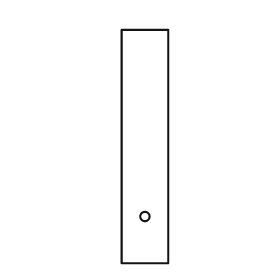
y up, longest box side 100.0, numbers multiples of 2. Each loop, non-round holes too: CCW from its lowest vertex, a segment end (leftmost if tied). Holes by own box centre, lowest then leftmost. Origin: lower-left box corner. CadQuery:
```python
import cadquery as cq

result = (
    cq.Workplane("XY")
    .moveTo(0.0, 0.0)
    .lineTo(20.0, 0.0)
    .lineTo(20.0, 100.0)
    .lineTo(0.0, 100.0)
    .close()
    .moveTo(10.0, 20.0)
    .circle(2.0)
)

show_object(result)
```